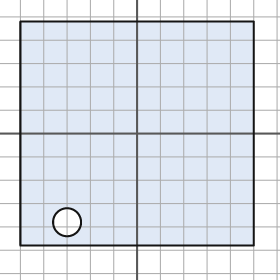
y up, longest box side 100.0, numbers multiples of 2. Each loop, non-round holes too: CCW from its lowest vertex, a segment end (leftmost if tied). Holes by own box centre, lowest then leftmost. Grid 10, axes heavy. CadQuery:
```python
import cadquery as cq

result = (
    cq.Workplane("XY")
    .moveTo(-50.0, -48.0)
    .lineTo(50.0, -48.0)
    .lineTo(50.0, 48.0)
    .lineTo(-50.0, 48.0)
    .close()
    .moveTo(-30.0, -38.0)
    .circle(6.0)
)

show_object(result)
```